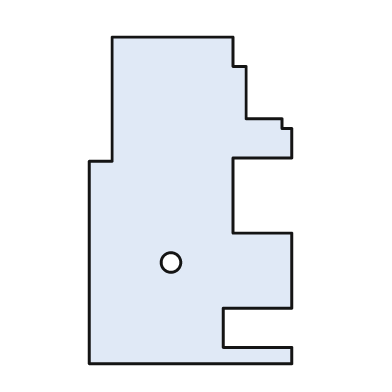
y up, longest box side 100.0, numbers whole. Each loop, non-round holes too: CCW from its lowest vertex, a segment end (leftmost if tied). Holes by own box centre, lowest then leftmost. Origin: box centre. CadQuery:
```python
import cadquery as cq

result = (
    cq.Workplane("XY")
    .moveTo(-31.0, -50.0)
    .lineTo(31.0, -50.0)
    .lineTo(31.0, -45.0)
    .lineTo(10.0, -45.0)
    .lineTo(10.0, -33.0)
    .lineTo(31.0, -33.0)
    .lineTo(31.0, -10.0)
    .lineTo(13.0, -10.0)
    .lineTo(13.0, 13.0)
    .lineTo(31.0, 13.0)
    .lineTo(31.0, 22.0)
    .lineTo(28.0, 22.0)
    .lineTo(28.0, 25.0)
    .lineTo(17.0, 25.0)
    .lineTo(17.0, 41.0)
    .lineTo(13.0, 41.0)
    .lineTo(13.0, 50.0)
    .lineTo(-24.0, 50.0)
    .lineTo(-24.0, 12.0)
    .lineTo(-31.0, 12.0)
    .close()
    .moveTo(-6.0, -19.0)
    .circle(3.0)
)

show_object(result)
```